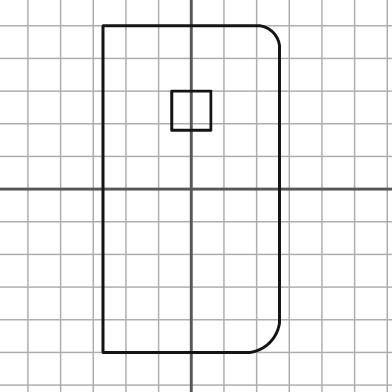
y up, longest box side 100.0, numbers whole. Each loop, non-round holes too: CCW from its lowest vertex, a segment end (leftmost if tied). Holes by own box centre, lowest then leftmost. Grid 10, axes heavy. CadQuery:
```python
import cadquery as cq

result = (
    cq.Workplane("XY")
    .moveTo(-27.0, -50.0)
    .lineTo(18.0, -50.0)
    .threePointArc((24.0, -47.0), (27.0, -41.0))
    .lineTo(27.0, 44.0)
    .threePointArc((25.0, 48.0), (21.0, 50.0))
    .lineTo(-27.0, 50.0)
    .close()
    .moveTo(-6.0, 18.0)
    .lineTo(6.0, 18.0)
    .lineTo(6.0, 30.0)
    .lineTo(-6.0, 30.0)
    .close()
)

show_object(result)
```